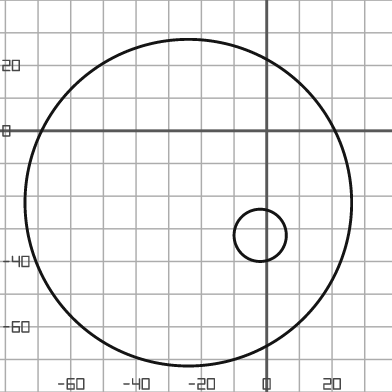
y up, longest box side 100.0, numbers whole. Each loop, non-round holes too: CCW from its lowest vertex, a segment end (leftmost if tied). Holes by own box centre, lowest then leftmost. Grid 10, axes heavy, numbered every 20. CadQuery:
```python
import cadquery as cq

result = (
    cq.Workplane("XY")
    .moveTo(-24.0, -22.0)
    .circle(50.0)
    .moveTo(-2.0, -32.0)
    .circle(8.0)
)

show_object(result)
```